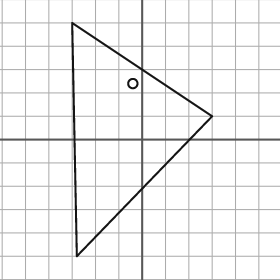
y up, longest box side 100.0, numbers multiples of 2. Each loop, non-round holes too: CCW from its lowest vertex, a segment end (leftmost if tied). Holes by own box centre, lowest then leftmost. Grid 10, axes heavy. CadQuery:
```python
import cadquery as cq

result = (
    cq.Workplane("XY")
    .moveTo(-28.0, -50.0)
    .lineTo(30.0, 10.0)
    .lineTo(-30.0, 50.0)
    .close()
    .moveTo(-4.0, 24.0)
    .circle(2.0)
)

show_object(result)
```